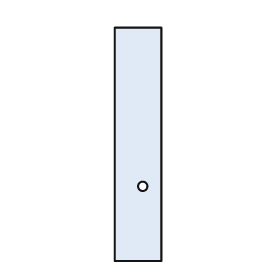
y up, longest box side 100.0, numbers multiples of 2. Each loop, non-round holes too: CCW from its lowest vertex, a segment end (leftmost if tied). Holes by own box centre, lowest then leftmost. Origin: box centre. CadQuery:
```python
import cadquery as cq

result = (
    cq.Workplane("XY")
    .moveTo(-10.0, -50.0)
    .lineTo(10.0, -50.0)
    .lineTo(10.0, 50.0)
    .lineTo(-10.0, 50.0)
    .close()
    .moveTo(2.0, -18.0)
    .circle(2.0)
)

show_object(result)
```